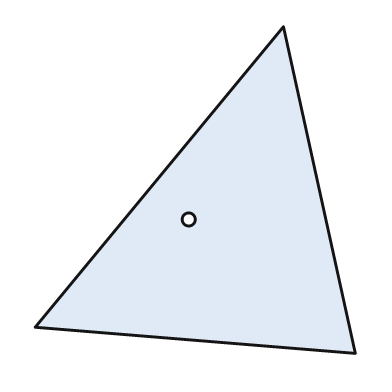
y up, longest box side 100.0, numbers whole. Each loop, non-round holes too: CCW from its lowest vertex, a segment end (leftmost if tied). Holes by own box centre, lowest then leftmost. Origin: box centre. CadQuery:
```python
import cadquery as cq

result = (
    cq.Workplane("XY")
    .moveTo(49.0, -50.0)
    .lineTo(27.0, 50.0)
    .lineTo(-49.0, -42.0)
    .close()
    .moveTo(-2.0, -9.0)
    .circle(2.0)
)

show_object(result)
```